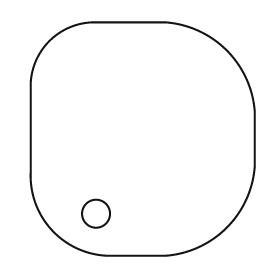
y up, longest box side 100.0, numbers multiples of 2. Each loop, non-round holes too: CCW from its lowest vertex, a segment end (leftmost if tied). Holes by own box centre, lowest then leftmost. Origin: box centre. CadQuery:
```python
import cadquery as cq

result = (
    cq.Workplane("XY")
    .moveTo(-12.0, -50.0)
    .lineTo(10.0, -50.0)
    .threePointArc((36.0, -38.0), (48.0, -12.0))
    .lineTo(48.0, 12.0)
    .threePointArc((36.0, 38.0), (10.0, 50.0))
    .lineTo(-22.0, 50.0)
    .threePointArc((-40.0, 42.0), (-48.0, 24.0))
    .lineTo(-48.0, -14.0)
    .threePointArc((-38.0, -40.0), (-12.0, -50.0))
    .close()
    .moveTo(-20.0, -32.0)
    .circle(6.0)
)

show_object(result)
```